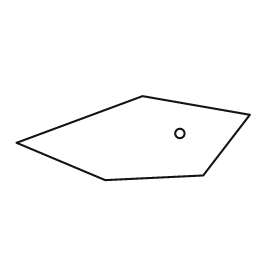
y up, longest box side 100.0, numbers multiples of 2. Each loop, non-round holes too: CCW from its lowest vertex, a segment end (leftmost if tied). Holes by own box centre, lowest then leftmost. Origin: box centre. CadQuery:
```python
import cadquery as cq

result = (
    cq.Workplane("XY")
    .moveTo(-12.0, -18.0)
    .lineTo(30.0, -16.0)
    .lineTo(50.0, 10.0)
    .lineTo(4.0, 18.0)
    .lineTo(-50.0, -2.0)
    .close()
    .moveTo(20.0, 2.0)
    .circle(2.0)
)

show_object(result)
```